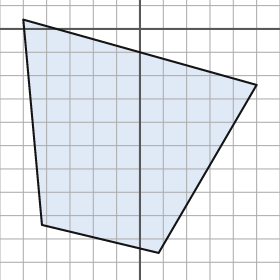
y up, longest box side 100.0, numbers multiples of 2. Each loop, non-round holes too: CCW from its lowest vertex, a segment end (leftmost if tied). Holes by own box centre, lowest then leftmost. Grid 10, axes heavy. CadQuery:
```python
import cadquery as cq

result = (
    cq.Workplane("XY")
    .moveTo(8.0, -96.0)
    .lineTo(50.0, -24.0)
    .lineTo(-50.0, 4.0)
    .lineTo(-42.0, -84.0)
    .close()
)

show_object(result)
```